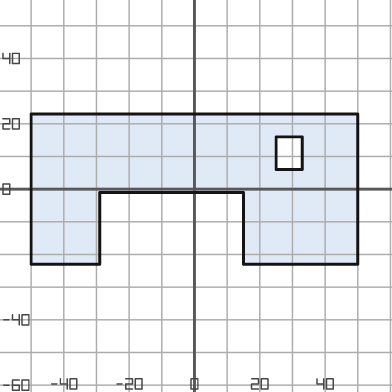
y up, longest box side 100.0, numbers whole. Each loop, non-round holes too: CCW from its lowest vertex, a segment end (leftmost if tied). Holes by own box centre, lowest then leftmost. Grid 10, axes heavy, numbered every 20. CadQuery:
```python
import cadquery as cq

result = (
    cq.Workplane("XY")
    .moveTo(-50.0, -23.0)
    .lineTo(-29.0, -23.0)
    .lineTo(-29.0, -1.0)
    .lineTo(15.0, -1.0)
    .lineTo(15.0, -23.0)
    .lineTo(50.0, -23.0)
    .lineTo(50.0, 23.0)
    .lineTo(-50.0, 23.0)
    .close()
    .moveTo(25.0, 6.0)
    .lineTo(33.0, 6.0)
    .lineTo(33.0, 16.0)
    .lineTo(25.0, 16.0)
    .close()
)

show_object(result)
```